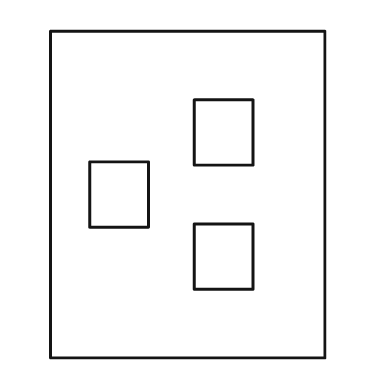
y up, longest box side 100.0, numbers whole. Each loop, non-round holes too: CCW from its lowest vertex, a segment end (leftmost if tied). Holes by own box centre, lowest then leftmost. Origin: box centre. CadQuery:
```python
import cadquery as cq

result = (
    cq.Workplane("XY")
    .moveTo(-42.0, -50.0)
    .lineTo(42.0, -50.0)
    .lineTo(42.0, 50.0)
    .lineTo(-42.0, 50.0)
    .close()
    .moveTo(2.0, -29.0)
    .lineTo(20.0, -29.0)
    .lineTo(20.0, -9.0)
    .lineTo(2.0, -9.0)
    .close()
    .moveTo(-30.0, -10.0)
    .lineTo(-12.0, -10.0)
    .lineTo(-12.0, 10.0)
    .lineTo(-30.0, 10.0)
    .close()
    .moveTo(2.0, 9.0)
    .lineTo(20.0, 9.0)
    .lineTo(20.0, 29.0)
    .lineTo(2.0, 29.0)
    .close()
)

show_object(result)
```